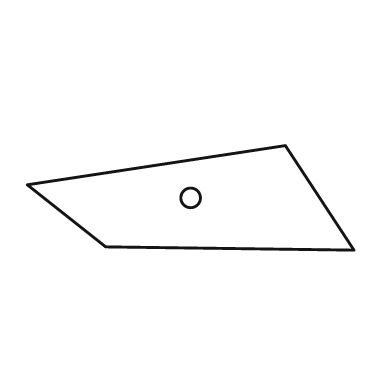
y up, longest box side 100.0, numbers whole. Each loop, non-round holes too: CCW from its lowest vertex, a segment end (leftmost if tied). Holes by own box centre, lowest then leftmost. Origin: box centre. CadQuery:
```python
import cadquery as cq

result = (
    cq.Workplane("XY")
    .moveTo(50.0, -16.0)
    .lineTo(29.0, 16.0)
    .lineTo(-50.0, 4.0)
    .lineTo(-26.0, -15.0)
    .close()
    .moveTo(0.0, 0.0)
    .circle(3.0)
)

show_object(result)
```